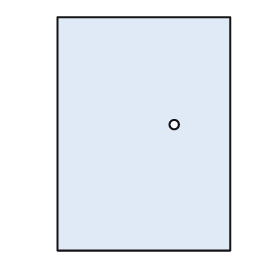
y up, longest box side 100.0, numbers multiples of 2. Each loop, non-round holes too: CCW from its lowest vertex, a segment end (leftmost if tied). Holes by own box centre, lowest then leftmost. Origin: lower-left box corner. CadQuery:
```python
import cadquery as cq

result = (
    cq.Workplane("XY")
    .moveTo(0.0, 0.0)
    .lineTo(74.0, 0.0)
    .lineTo(74.0, 100.0)
    .lineTo(0.0, 100.0)
    .close()
    .moveTo(50.0, 54.0)
    .circle(2.0)
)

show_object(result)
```